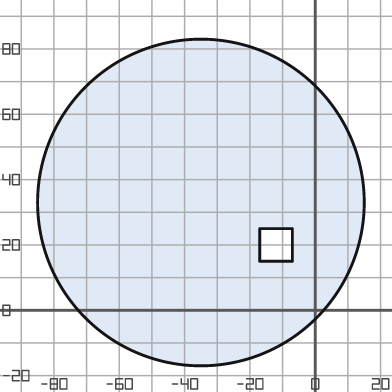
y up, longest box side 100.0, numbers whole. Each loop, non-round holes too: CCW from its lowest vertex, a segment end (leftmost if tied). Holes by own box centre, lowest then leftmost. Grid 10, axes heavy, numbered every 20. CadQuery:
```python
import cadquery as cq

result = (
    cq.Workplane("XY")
    .moveTo(-35.0, 33.0)
    .circle(50.0)
    .moveTo(-17.0, 15.0)
    .lineTo(-7.0, 15.0)
    .lineTo(-7.0, 25.0)
    .lineTo(-17.0, 25.0)
    .close()
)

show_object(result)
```